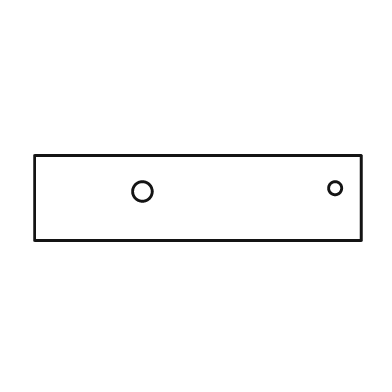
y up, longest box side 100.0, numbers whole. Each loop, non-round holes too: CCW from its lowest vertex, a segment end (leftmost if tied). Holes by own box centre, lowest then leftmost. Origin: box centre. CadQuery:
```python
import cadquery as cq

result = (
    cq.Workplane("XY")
    .moveTo(-50.0, -13.0)
    .lineTo(50.0, -13.0)
    .lineTo(50.0, 13.0)
    .lineTo(-50.0, 13.0)
    .close()
    .moveTo(-17.0, 2.0)
    .circle(3.0)
    .moveTo(42.0, 3.0)
    .circle(2.0)
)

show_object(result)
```